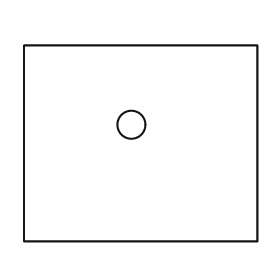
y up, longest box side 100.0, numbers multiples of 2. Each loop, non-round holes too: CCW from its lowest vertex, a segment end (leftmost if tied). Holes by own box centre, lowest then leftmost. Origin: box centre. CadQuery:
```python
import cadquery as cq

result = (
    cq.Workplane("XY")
    .moveTo(-50.0, -42.0)
    .lineTo(50.0, -42.0)
    .lineTo(50.0, 42.0)
    .lineTo(-50.0, 42.0)
    .close()
    .moveTo(-4.0, 8.0)
    .circle(6.0)
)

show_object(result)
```